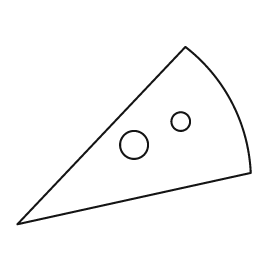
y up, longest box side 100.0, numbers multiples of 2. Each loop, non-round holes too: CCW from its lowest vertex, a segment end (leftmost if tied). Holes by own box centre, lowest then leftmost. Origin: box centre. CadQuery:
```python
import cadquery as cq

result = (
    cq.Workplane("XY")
    .moveTo(-50.0, -38.0)
    .lineTo(50.0, -16.0)
    .threePointArc((42.0, 14.0), (22.0, 38.0))
    .close()
    .moveTo(0.0, -4.0)
    .circle(6.0)
    .moveTo(20.0, 6.0)
    .circle(4.0)
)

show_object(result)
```